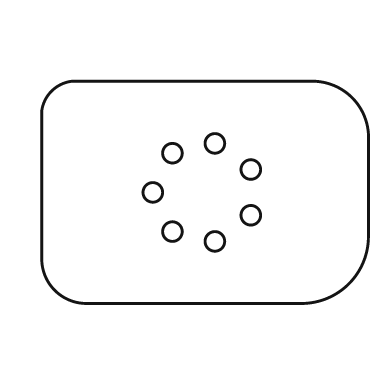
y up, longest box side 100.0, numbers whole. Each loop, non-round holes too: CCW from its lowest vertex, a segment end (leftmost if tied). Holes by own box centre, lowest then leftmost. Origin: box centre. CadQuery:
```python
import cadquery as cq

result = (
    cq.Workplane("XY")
    .moveTo(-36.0, -34.0)
    .lineTo(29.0, -34.0)
    .threePointArc((44.0, -28.0), (50.0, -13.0))
    .lineTo(50.0, 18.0)
    .threePointArc((45.0, 29.0), (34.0, 34.0))
    .lineTo(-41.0, 34.0)
    .threePointArc((-47.0, 31.0), (-50.0, 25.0))
    .lineTo(-50.0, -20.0)
    .threePointArc((-46.0, -30.0), (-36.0, -34.0))
    .close()
    .moveTo(3.0, -15.0)
    .circle(3.0)
    .moveTo(-10.0, -12.0)
    .circle(3.0)
    .moveTo(14.0, -7.0)
    .circle(3.0)
    .moveTo(-16.0, 0.0)
    .circle(3.0)
    .moveTo(14.0, 7.0)
    .circle(3.0)
    .moveTo(-10.0, 12.0)
    .circle(3.0)
    .moveTo(3.0, 15.0)
    .circle(3.0)
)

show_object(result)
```